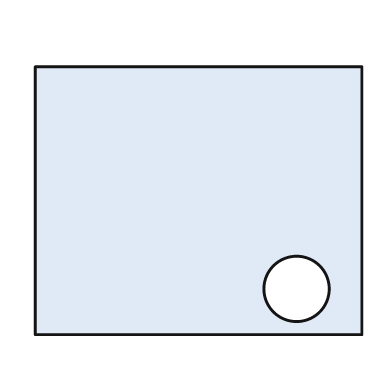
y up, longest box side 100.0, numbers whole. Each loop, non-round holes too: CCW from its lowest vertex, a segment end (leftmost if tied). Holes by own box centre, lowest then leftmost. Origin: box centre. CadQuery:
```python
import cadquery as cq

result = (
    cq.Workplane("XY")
    .moveTo(-50.0, -41.0)
    .lineTo(50.0, -41.0)
    .lineTo(50.0, 41.0)
    .lineTo(-50.0, 41.0)
    .close()
    .moveTo(30.0, -27.0)
    .circle(10.0)
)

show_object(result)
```